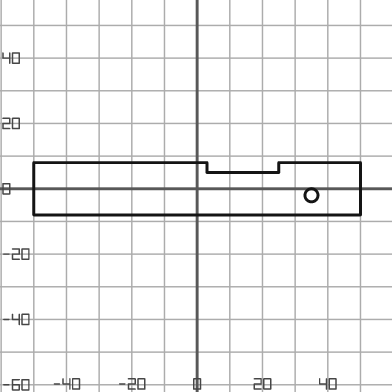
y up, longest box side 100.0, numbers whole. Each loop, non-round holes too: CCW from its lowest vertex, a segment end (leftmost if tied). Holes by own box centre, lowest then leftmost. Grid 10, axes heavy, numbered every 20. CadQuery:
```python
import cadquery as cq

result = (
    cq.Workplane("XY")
    .moveTo(-50.0, -8.0)
    .lineTo(50.0, -8.0)
    .lineTo(50.0, 8.0)
    .lineTo(25.0, 8.0)
    .lineTo(25.0, 5.0)
    .lineTo(3.0, 5.0)
    .lineTo(3.0, 8.0)
    .lineTo(-50.0, 8.0)
    .close()
    .moveTo(35.0, -2.0)
    .circle(2.0)
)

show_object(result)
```